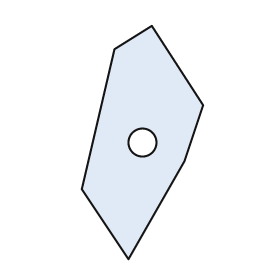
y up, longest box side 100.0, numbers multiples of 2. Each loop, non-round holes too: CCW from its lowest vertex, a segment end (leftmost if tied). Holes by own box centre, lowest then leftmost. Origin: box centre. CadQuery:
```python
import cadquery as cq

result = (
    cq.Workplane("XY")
    .moveTo(-6.0, -50.0)
    .lineTo(18.0, -8.0)
    .lineTo(26.0, 16.0)
    .lineTo(4.0, 50.0)
    .lineTo(-12.0, 40.0)
    .lineTo(-26.0, -20.0)
    .close()
    .moveTo(0.0, 0.0)
    .circle(6.0)
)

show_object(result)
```